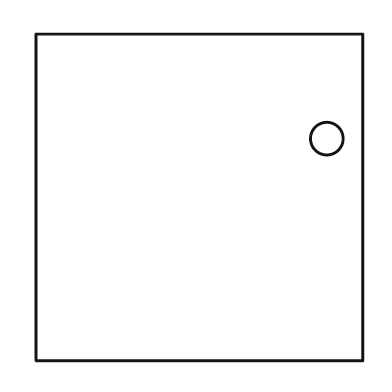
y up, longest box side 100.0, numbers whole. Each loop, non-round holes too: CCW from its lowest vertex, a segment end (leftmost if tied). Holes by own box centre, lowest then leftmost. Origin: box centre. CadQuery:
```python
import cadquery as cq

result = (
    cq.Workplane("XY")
    .moveTo(-50.0, -50.0)
    .lineTo(50.0, -50.0)
    .lineTo(50.0, 50.0)
    .lineTo(-50.0, 50.0)
    .close()
    .moveTo(39.0, 18.0)
    .circle(5.0)
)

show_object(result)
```